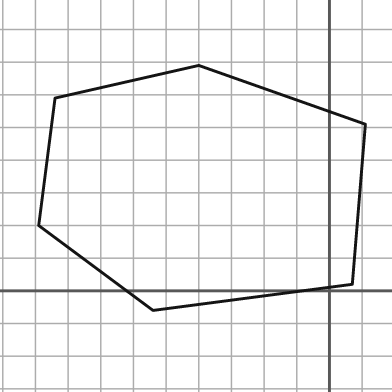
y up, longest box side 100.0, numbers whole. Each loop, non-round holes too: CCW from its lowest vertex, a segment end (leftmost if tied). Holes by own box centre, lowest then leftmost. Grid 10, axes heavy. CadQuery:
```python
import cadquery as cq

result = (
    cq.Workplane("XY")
    .moveTo(-54.0, -6.0)
    .lineTo(7.0, 2.0)
    .lineTo(11.0, 51.0)
    .lineTo(-40.0, 69.0)
    .lineTo(-84.0, 59.0)
    .lineTo(-89.0, 20.0)
    .close()
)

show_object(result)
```